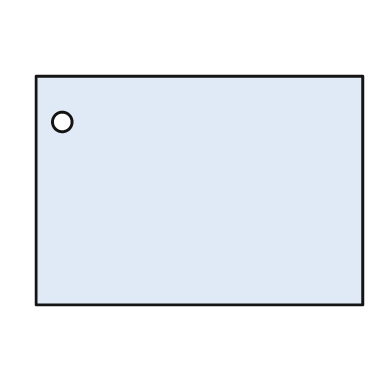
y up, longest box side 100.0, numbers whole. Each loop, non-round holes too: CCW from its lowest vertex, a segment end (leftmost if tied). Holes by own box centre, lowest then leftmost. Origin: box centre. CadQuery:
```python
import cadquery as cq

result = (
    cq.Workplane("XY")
    .moveTo(-50.0, -35.0)
    .lineTo(50.0, -35.0)
    .lineTo(50.0, 35.0)
    .lineTo(-50.0, 35.0)
    .close()
    .moveTo(-42.0, 21.0)
    .circle(3.0)
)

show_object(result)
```